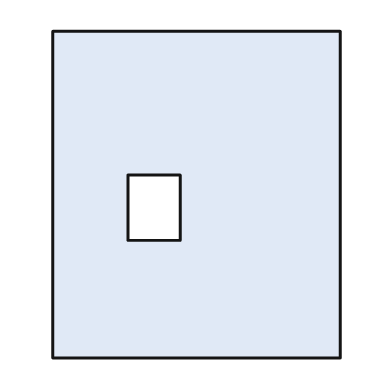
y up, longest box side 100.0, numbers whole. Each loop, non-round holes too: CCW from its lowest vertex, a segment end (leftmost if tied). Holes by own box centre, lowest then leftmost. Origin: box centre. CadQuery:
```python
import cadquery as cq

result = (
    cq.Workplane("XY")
    .moveTo(-44.0, -50.0)
    .lineTo(44.0, -50.0)
    .lineTo(44.0, 50.0)
    .lineTo(-44.0, 50.0)
    .close()
    .moveTo(-21.0, -14.0)
    .lineTo(-5.0, -14.0)
    .lineTo(-5.0, 6.0)
    .lineTo(-21.0, 6.0)
    .close()
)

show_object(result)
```